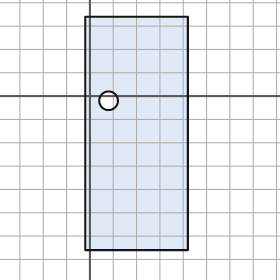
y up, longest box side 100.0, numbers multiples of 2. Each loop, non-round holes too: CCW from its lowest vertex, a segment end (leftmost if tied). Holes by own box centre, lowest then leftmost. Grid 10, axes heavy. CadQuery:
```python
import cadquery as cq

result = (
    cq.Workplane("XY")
    .moveTo(-2.0, -66.0)
    .lineTo(42.0, -66.0)
    .lineTo(42.0, 34.0)
    .lineTo(-2.0, 34.0)
    .close()
    .moveTo(8.0, -2.0)
    .circle(4.0)
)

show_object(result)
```